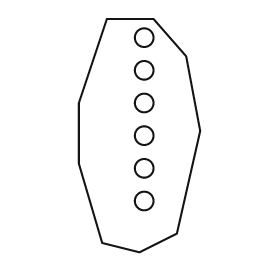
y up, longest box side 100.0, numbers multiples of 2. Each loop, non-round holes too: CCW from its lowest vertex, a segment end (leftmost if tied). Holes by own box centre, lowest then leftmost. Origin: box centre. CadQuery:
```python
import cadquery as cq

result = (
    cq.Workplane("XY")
    .moveTo(0.0, -50.0)
    .lineTo(16.0, -42.0)
    .lineTo(26.0, 2.0)
    .lineTo(20.0, 34.0)
    .lineTo(6.0, 50.0)
    .lineTo(-14.0, 50.0)
    .lineTo(-26.0, 14.0)
    .lineTo(-26.0, -12.0)
    .lineTo(-16.0, -46.0)
    .close()
    .moveTo(2.0, -28.0)
    .circle(4.0)
    .moveTo(2.0, -14.0)
    .circle(4.0)
    .moveTo(2.0, 0.0)
    .circle(4.0)
    .moveTo(2.0, 14.0)
    .circle(4.0)
    .moveTo(2.0, 28.0)
    .circle(4.0)
    .moveTo(2.0, 42.0)
    .circle(4.0)
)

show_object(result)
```